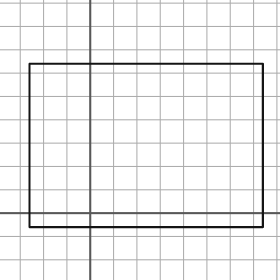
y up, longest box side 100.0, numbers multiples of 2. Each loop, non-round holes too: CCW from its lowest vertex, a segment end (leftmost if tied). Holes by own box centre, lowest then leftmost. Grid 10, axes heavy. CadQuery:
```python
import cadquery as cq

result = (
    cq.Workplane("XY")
    .moveTo(-26.0, -6.0)
    .lineTo(74.0, -6.0)
    .lineTo(74.0, 64.0)
    .lineTo(-26.0, 64.0)
    .close()
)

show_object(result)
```